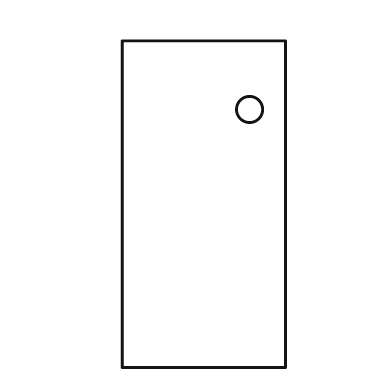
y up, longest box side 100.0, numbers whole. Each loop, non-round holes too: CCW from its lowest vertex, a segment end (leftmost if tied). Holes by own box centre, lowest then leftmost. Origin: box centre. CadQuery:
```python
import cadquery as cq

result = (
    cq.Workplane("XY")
    .moveTo(-25.0, -50.0)
    .lineTo(25.0, -50.0)
    .lineTo(25.0, 50.0)
    .lineTo(-25.0, 50.0)
    .close()
    .moveTo(14.0, 29.0)
    .circle(4.0)
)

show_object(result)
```